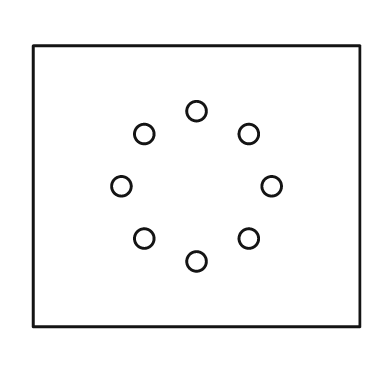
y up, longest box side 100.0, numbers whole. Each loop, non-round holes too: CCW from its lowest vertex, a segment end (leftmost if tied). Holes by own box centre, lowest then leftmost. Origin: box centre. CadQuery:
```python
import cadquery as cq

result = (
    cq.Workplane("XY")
    .moveTo(-50.0, -43.0)
    .lineTo(50.0, -43.0)
    .lineTo(50.0, 43.0)
    .lineTo(-50.0, 43.0)
    .close()
    .moveTo(0.0, -23.0)
    .circle(3.0)
    .moveTo(-16.0, -16.0)
    .circle(3.0)
    .moveTo(16.0, -16.0)
    .circle(3.0)
    .moveTo(-23.0, 0.0)
    .circle(3.0)
    .moveTo(23.0, 0.0)
    .circle(3.0)
    .moveTo(-16.0, 16.0)
    .circle(3.0)
    .moveTo(16.0, 16.0)
    .circle(3.0)
    .moveTo(0.0, 23.0)
    .circle(3.0)
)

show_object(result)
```